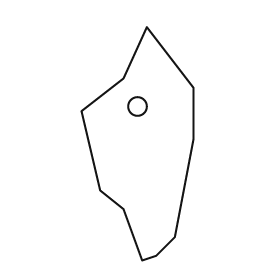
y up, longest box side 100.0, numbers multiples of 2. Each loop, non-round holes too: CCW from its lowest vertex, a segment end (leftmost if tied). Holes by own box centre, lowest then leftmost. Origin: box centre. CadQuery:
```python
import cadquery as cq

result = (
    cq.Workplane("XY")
    .moveTo(2.0, -50.0)
    .lineTo(8.0, -48.0)
    .lineTo(16.0, -40.0)
    .lineTo(24.0, 2.0)
    .lineTo(24.0, 24.0)
    .lineTo(4.0, 50.0)
    .lineTo(-6.0, 28.0)
    .lineTo(-24.0, 14.0)
    .lineTo(-16.0, -20.0)
    .lineTo(-6.0, -28.0)
    .close()
    .moveTo(0.0, 16.0)
    .circle(4.0)
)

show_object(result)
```